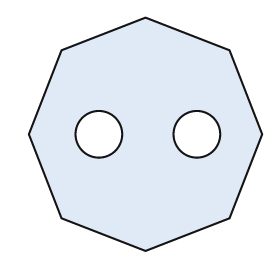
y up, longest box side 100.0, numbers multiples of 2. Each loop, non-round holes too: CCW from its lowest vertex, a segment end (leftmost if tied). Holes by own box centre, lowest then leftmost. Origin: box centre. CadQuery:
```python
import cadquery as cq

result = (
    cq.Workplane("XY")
    .moveTo(0.0, -50.0)
    .lineTo(36.0, -36.0)
    .lineTo(50.0, 0.0)
    .lineTo(36.0, 36.0)
    .lineTo(0.0, 50.0)
    .lineTo(-36.0, 36.0)
    .lineTo(-50.0, 0.0)
    .lineTo(-36.0, -36.0)
    .close()
    .moveTo(-20.0, 0.0)
    .circle(10.0)
    .moveTo(22.0, 0.0)
    .circle(10.0)
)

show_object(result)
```